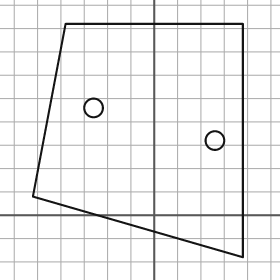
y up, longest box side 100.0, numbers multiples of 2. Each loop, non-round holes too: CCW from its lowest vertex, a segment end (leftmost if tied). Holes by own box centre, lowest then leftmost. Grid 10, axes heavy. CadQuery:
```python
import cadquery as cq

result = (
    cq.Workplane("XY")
    .moveTo(38.0, -18.0)
    .lineTo(38.0, 82.0)
    .lineTo(-38.0, 82.0)
    .lineTo(-52.0, 8.0)
    .close()
    .moveTo(26.0, 32.0)
    .circle(4.0)
    .moveTo(-26.0, 46.0)
    .circle(4.0)
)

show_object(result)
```